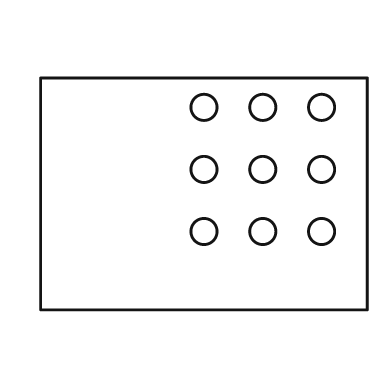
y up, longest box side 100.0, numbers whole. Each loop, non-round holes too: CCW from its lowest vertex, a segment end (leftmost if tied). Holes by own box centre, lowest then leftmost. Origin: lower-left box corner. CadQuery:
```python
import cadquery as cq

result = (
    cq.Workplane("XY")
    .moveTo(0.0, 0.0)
    .lineTo(100.0, 0.0)
    .lineTo(100.0, 71.0)
    .lineTo(0.0, 71.0)
    .close()
    .moveTo(50.0, 24.0)
    .circle(4.0)
    .moveTo(68.0, 24.0)
    .circle(4.0)
    .moveTo(86.0, 24.0)
    .circle(4.0)
    .moveTo(50.0, 43.0)
    .circle(4.0)
    .moveTo(68.0, 43.0)
    .circle(4.0)
    .moveTo(86.0, 43.0)
    .circle(4.0)
    .moveTo(50.0, 62.0)
    .circle(4.0)
    .moveTo(68.0, 62.0)
    .circle(4.0)
    .moveTo(86.0, 62.0)
    .circle(4.0)
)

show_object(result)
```